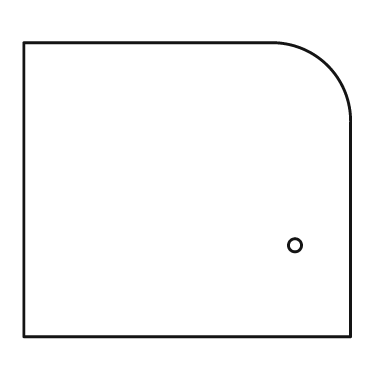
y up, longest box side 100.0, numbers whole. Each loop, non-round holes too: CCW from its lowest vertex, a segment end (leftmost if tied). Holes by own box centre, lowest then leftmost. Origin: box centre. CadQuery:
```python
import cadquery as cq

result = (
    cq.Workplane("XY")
    .moveTo(-50.0, -45.0)
    .lineTo(50.0, -45.0)
    .lineTo(50.0, 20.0)
    .threePointArc((43.0, 38.0), (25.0, 45.0))
    .lineTo(-50.0, 45.0)
    .close()
    .moveTo(33.0, -17.0)
    .circle(2.0)
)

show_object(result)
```